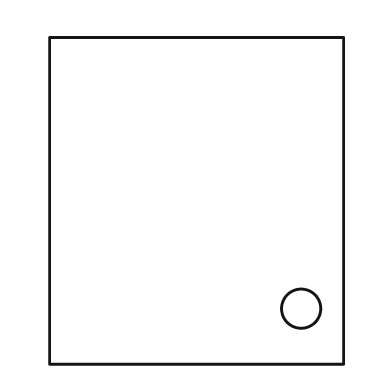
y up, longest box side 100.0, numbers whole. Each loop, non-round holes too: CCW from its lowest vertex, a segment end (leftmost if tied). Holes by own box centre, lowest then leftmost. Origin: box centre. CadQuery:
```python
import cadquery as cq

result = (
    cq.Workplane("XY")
    .moveTo(-45.0, -50.0)
    .lineTo(45.0, -50.0)
    .lineTo(45.0, 50.0)
    .lineTo(-45.0, 50.0)
    .close()
    .moveTo(32.0, -33.0)
    .circle(6.0)
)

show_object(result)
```